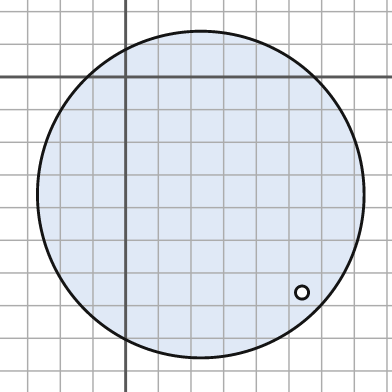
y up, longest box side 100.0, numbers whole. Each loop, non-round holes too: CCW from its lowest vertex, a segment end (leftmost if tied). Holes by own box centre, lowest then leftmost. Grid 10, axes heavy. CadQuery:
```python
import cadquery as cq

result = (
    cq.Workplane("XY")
    .moveTo(23.0, -36.0)
    .circle(50.0)
    .moveTo(54.0, -66.0)
    .circle(2.0)
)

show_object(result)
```